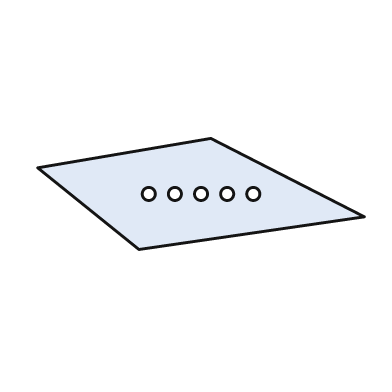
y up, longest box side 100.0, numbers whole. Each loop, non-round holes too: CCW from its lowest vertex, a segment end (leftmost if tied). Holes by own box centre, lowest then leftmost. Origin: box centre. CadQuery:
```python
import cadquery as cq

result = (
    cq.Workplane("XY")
    .moveTo(-19.0, -17.0)
    .lineTo(50.0, -7.0)
    .lineTo(3.0, 17.0)
    .lineTo(-50.0, 8.0)
    .close()
    .moveTo(-16.0, 0.0)
    .circle(2.0)
    .moveTo(-8.0, 0.0)
    .circle(2.0)
    .moveTo(0.0, 0.0)
    .circle(2.0)
    .moveTo(8.0, 0.0)
    .circle(2.0)
    .moveTo(16.0, 0.0)
    .circle(2.0)
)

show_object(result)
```